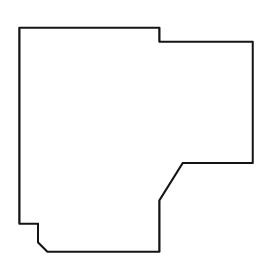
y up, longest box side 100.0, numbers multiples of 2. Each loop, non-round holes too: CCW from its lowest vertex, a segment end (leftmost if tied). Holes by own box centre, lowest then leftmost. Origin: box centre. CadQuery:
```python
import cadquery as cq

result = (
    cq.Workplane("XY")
    .moveTo(-38.0, -48.0)
    .lineTo(10.0, -48.0)
    .lineTo(10.0, -26.0)
    .lineTo(20.0, -10.0)
    .lineTo(50.0, -10.0)
    .lineTo(50.0, 42.0)
    .lineTo(10.0, 42.0)
    .lineTo(10.0, 48.0)
    .lineTo(-50.0, 48.0)
    .lineTo(-50.0, -36.0)
    .lineTo(-42.0, -36.0)
    .lineTo(-42.0, -44.0)
    .close()
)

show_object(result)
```